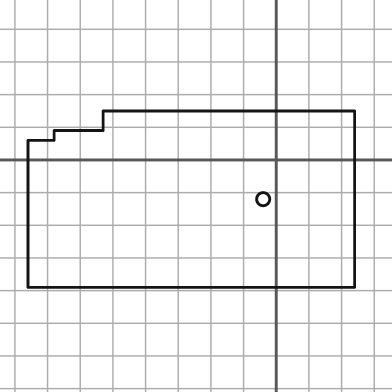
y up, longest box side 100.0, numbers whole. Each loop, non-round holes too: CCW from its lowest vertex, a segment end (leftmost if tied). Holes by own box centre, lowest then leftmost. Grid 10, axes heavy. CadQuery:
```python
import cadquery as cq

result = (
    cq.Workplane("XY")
    .moveTo(-76.0, -39.0)
    .lineTo(24.0, -39.0)
    .lineTo(24.0, 15.0)
    .lineTo(-53.0, 15.0)
    .lineTo(-53.0, 9.0)
    .lineTo(-68.0, 9.0)
    .lineTo(-68.0, 6.0)
    .lineTo(-76.0, 6.0)
    .close()
    .moveTo(-4.0, -12.0)
    .circle(2.0)
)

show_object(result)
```